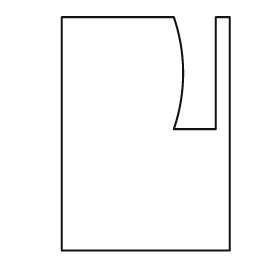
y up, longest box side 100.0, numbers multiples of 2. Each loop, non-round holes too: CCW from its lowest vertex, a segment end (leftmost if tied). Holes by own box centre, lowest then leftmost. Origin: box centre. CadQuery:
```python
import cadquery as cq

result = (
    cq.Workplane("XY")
    .moveTo(-36.0, -50.0)
    .lineTo(36.0, -50.0)
    .lineTo(36.0, 50.0)
    .lineTo(30.0, 50.0)
    .lineTo(30.0, 2.0)
    .lineTo(12.0, 2.0)
    .threePointArc((16.0, 26.0), (12.0, 50.0))
    .lineTo(-36.0, 50.0)
    .close()
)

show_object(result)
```